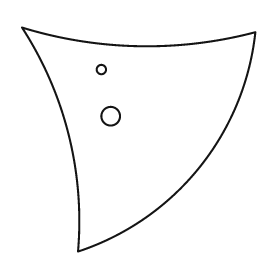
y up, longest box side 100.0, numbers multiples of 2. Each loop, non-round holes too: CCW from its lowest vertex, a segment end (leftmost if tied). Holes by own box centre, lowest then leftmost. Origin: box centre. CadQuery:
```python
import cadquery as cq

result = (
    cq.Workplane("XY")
    .moveTo(-26.0, -48.0)
    .threePointArc((26.0, -12.0), (50.0, 46.0))
    .threePointArc((0.0, 40.0), (-50.0, 48.0))
    .threePointArc((-30.0, 2.0), (-26.0, -48.0))
    .close()
    .moveTo(-12.0, 10.0)
    .circle(4.0)
    .moveTo(-16.0, 30.0)
    .circle(2.0)
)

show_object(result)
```